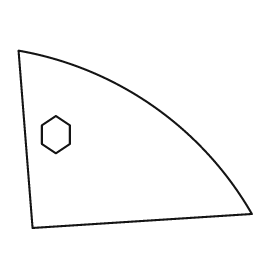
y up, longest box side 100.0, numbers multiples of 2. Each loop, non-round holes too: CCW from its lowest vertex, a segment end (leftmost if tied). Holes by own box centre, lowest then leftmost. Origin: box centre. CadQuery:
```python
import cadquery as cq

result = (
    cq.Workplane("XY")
    .moveTo(-44.0, -38.0)
    .lineTo(50.0, -32.0)
    .threePointArc((8.0, 14.0), (-50.0, 38.0))
    .close()
    .moveTo(-34.0, -6.0)
    .lineTo(-28.0, -2.0)
    .lineTo(-28.0, 6.0)
    .lineTo(-34.0, 10.0)
    .lineTo(-40.0, 6.0)
    .lineTo(-40.0, -2.0)
    .close()
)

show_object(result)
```